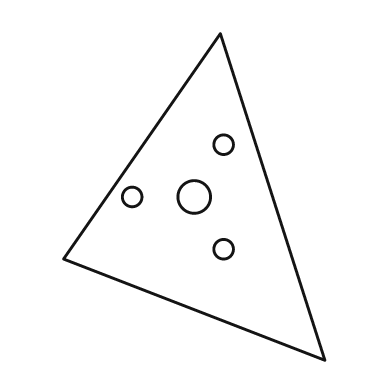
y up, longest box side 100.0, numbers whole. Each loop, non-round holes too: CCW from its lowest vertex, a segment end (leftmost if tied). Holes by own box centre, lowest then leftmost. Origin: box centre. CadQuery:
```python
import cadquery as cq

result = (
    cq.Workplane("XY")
    .moveTo(40.0, -50.0)
    .lineTo(8.0, 50.0)
    .lineTo(-40.0, -19.0)
    .close()
    .moveTo(9.0, -16.0)
    .circle(3.0)
    .moveTo(-19.0, 0.0)
    .circle(3.0)
    .moveTo(0.0, 0.0)
    .circle(5.0)
    .moveTo(9.0, 16.0)
    .circle(3.0)
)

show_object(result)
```